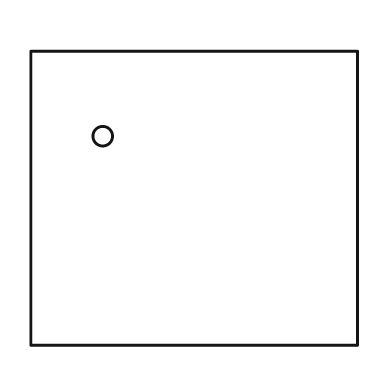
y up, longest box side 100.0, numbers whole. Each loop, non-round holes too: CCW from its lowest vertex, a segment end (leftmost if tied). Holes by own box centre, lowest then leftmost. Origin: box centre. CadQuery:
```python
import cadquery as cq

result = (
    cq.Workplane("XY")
    .moveTo(-50.0, -45.0)
    .lineTo(50.0, -45.0)
    .lineTo(50.0, 45.0)
    .lineTo(-50.0, 45.0)
    .close()
    .moveTo(-28.0, 19.0)
    .circle(3.0)
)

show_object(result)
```